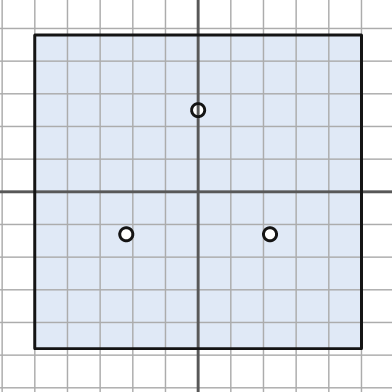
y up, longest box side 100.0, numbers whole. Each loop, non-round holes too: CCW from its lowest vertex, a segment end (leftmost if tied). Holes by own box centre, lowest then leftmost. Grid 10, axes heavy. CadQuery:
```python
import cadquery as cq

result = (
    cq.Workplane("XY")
    .moveTo(-50.0, -48.0)
    .lineTo(50.0, -48.0)
    .lineTo(50.0, 48.0)
    .lineTo(-50.0, 48.0)
    .close()
    .moveTo(-22.0, -13.0)
    .circle(2.0)
    .moveTo(22.0, -13.0)
    .circle(2.0)
    .moveTo(0.0, 25.0)
    .circle(2.0)
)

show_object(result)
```